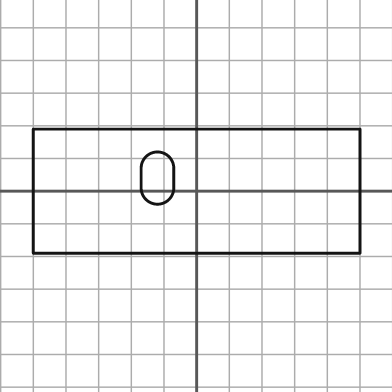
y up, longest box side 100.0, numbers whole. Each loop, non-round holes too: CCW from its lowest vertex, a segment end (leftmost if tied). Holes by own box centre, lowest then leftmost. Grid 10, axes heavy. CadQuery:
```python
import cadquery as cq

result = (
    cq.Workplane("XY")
    .moveTo(-50.0, -19.0)
    .lineTo(50.0, -19.0)
    .lineTo(50.0, 19.0)
    .lineTo(-50.0, 19.0)
    .close()
    .moveTo(-17.0, 1.0)
    .threePointArc((-12.0, -4.0), (-7.0, 1.0))
    .lineTo(-7.0, 7.0)
    .threePointArc((-12.0, 12.0), (-17.0, 7.0))
    .close()
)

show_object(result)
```